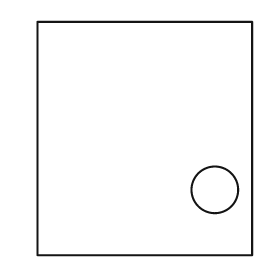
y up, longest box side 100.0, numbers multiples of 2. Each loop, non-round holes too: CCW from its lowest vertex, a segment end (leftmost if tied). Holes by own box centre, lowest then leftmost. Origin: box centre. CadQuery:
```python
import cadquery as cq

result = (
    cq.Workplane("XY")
    .moveTo(-46.0, -50.0)
    .lineTo(46.0, -50.0)
    .lineTo(46.0, 50.0)
    .lineTo(-46.0, 50.0)
    .close()
    .moveTo(30.0, -22.0)
    .circle(10.0)
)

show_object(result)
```